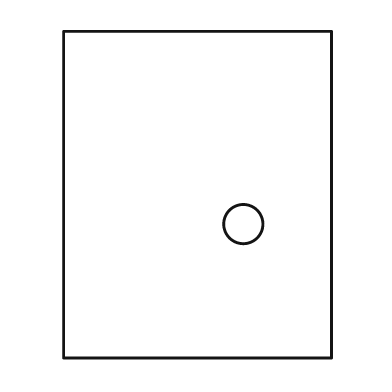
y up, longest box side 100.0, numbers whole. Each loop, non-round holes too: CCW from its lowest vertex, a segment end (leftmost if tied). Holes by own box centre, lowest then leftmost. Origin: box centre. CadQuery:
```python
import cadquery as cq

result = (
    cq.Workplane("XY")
    .moveTo(-41.0, -50.0)
    .lineTo(41.0, -50.0)
    .lineTo(41.0, 50.0)
    .lineTo(-41.0, 50.0)
    .close()
    .moveTo(14.0, -9.0)
    .circle(6.0)
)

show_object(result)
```